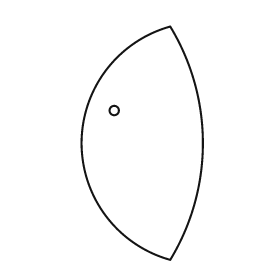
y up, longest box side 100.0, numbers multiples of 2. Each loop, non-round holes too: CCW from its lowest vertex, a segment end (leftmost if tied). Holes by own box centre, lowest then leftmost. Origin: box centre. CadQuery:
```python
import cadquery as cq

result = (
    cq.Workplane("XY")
    .moveTo(12.0, -50.0)
    .threePointArc((26.0, 0.0), (12.0, 50.0))
    .threePointArc((-26.0, 0.0), (12.0, -50.0))
    .close()
    .moveTo(-12.0, 14.0)
    .circle(2.0)
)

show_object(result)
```